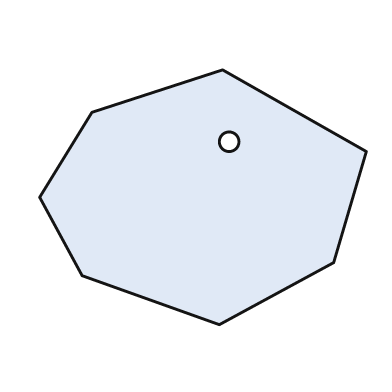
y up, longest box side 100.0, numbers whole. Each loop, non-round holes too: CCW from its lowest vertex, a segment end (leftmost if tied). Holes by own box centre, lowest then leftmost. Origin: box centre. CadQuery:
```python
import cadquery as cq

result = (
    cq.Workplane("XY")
    .moveTo(5.0, -39.0)
    .lineTo(40.0, -20.0)
    .lineTo(50.0, 14.0)
    .lineTo(6.0, 39.0)
    .lineTo(-34.0, 26.0)
    .lineTo(-50.0, 0.0)
    .lineTo(-37.0, -24.0)
    .close()
    .moveTo(8.0, 17.0)
    .circle(3.0)
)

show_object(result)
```